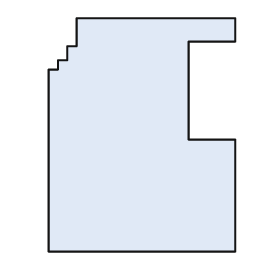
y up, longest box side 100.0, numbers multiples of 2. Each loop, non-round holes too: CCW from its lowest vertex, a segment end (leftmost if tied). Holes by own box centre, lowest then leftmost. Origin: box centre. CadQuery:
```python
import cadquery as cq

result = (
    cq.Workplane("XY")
    .moveTo(-40.0, -50.0)
    .lineTo(40.0, -50.0)
    .lineTo(40.0, -2.0)
    .lineTo(20.0, -2.0)
    .lineTo(20.0, 40.0)
    .lineTo(40.0, 40.0)
    .lineTo(40.0, 50.0)
    .lineTo(-28.0, 50.0)
    .lineTo(-28.0, 38.0)
    .lineTo(-32.0, 38.0)
    .lineTo(-32.0, 32.0)
    .lineTo(-36.0, 32.0)
    .lineTo(-36.0, 28.0)
    .lineTo(-40.0, 28.0)
    .close()
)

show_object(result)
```